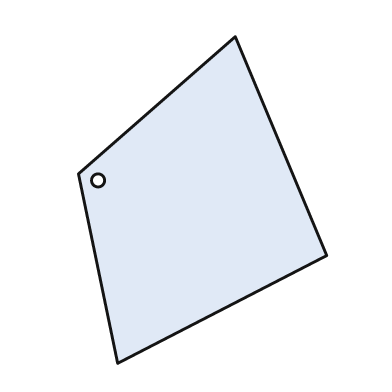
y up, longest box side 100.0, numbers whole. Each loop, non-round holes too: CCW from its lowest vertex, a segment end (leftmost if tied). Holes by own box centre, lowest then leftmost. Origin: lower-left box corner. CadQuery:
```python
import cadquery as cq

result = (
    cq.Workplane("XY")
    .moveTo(12.0, 0.0)
    .lineTo(76.0, 33.0)
    .lineTo(48.0, 100.0)
    .lineTo(0.0, 58.0)
    .close()
    .moveTo(6.0, 56.0)
    .circle(2.0)
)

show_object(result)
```